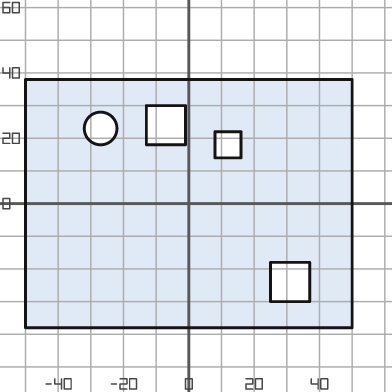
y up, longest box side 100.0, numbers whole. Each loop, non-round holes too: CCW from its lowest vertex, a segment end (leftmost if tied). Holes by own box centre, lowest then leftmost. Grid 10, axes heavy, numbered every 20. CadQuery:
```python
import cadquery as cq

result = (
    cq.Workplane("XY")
    .moveTo(-50.0, -38.0)
    .lineTo(50.0, -38.0)
    .lineTo(50.0, 38.0)
    .lineTo(-50.0, 38.0)
    .close()
    .moveTo(25.0, -30.0)
    .lineTo(37.0, -30.0)
    .lineTo(37.0, -18.0)
    .lineTo(25.0, -18.0)
    .close()
    .moveTo(8.0, 14.0)
    .lineTo(16.0, 14.0)
    .lineTo(16.0, 22.0)
    .lineTo(8.0, 22.0)
    .close()
    .moveTo(-27.0, 23.0)
    .circle(5.0)
    .moveTo(-13.0, 18.0)
    .lineTo(-1.0, 18.0)
    .lineTo(-1.0, 30.0)
    .lineTo(-13.0, 30.0)
    .close()
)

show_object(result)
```